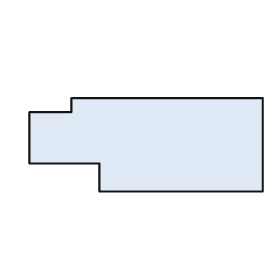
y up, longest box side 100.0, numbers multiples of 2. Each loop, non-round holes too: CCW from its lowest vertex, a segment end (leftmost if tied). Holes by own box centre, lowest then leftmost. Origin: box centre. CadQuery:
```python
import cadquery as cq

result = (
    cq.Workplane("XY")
    .moveTo(-20.0, -20.0)
    .lineTo(50.0, -20.0)
    .lineTo(50.0, 20.0)
    .lineTo(-32.0, 20.0)
    .lineTo(-32.0, 14.0)
    .lineTo(-50.0, 14.0)
    .lineTo(-50.0, -8.0)
    .lineTo(-20.0, -8.0)
    .close()
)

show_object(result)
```